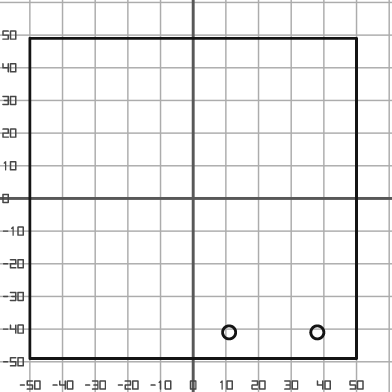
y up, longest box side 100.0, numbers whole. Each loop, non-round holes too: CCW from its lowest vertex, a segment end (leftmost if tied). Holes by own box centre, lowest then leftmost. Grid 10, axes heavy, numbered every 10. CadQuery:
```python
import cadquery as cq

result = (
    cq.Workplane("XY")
    .moveTo(-50.0, -49.0)
    .lineTo(50.0, -49.0)
    .lineTo(50.0, 49.0)
    .lineTo(-50.0, 49.0)
    .close()
    .moveTo(11.0, -41.0)
    .circle(2.0)
    .moveTo(38.0, -41.0)
    .circle(2.0)
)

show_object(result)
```